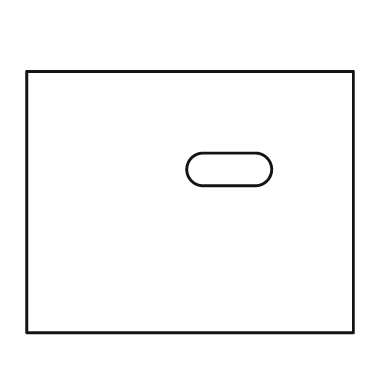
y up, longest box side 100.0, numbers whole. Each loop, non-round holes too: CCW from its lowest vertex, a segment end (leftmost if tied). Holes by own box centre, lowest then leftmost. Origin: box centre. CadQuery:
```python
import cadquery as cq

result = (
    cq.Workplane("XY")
    .moveTo(-50.0, -40.0)
    .lineTo(50.0, -40.0)
    .lineTo(50.0, 40.0)
    .lineTo(-50.0, 40.0)
    .close()
    .moveTo(4.0, 5.0)
    .lineTo(20.0, 5.0)
    .threePointArc((25.0, 10.0), (20.0, 15.0))
    .lineTo(4.0, 15.0)
    .threePointArc((-1.0, 10.0), (4.0, 5.0))
    .close()
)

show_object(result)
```